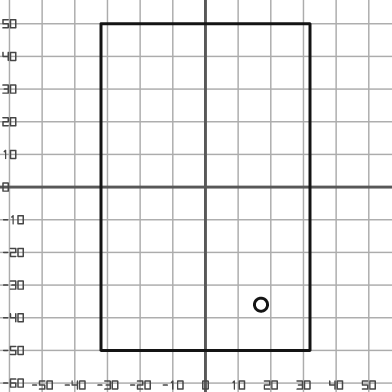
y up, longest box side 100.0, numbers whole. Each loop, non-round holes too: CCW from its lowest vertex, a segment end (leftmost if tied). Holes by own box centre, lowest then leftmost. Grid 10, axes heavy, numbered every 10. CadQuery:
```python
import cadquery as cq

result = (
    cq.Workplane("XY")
    .moveTo(-32.0, -50.0)
    .lineTo(32.0, -50.0)
    .lineTo(32.0, 50.0)
    .lineTo(-32.0, 50.0)
    .close()
    .moveTo(17.0, -36.0)
    .circle(2.0)
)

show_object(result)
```